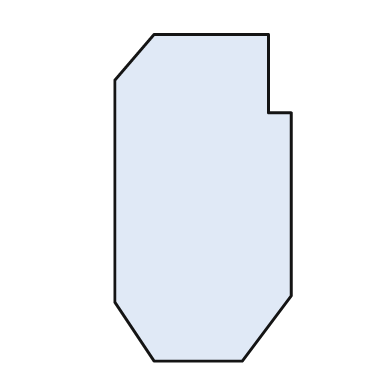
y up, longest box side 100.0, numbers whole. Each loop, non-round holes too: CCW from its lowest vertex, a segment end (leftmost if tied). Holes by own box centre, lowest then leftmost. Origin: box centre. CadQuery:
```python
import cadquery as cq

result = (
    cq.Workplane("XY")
    .moveTo(-15.0, -50.0)
    .lineTo(12.0, -50.0)
    .lineTo(27.0, -30.0)
    .lineTo(27.0, 26.0)
    .lineTo(20.0, 26.0)
    .lineTo(20.0, 50.0)
    .lineTo(-15.0, 50.0)
    .lineTo(-27.0, 36.0)
    .lineTo(-27.0, -32.0)
    .close()
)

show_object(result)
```